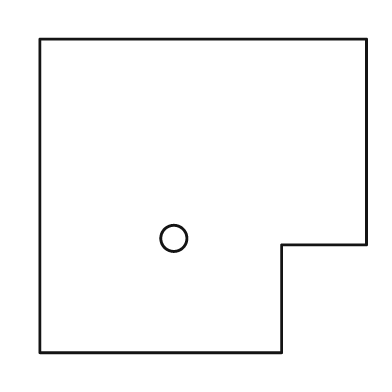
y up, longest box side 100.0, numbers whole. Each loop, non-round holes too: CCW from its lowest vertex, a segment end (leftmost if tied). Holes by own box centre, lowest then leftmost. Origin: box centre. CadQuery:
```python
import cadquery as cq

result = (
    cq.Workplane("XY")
    .moveTo(-50.0, -48.0)
    .lineTo(24.0, -48.0)
    .lineTo(24.0, -15.0)
    .lineTo(50.0, -15.0)
    .lineTo(50.0, 48.0)
    .lineTo(-50.0, 48.0)
    .close()
    .moveTo(-9.0, -13.0)
    .circle(4.0)
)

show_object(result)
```